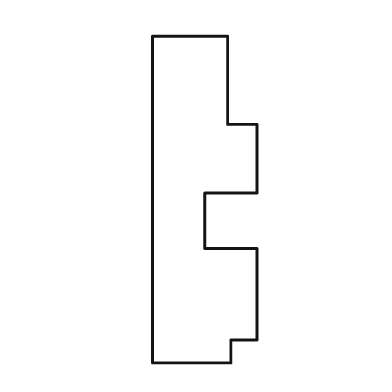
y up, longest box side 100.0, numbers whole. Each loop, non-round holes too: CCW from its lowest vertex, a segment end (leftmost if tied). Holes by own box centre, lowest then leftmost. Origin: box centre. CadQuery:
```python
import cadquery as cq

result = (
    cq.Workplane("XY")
    .moveTo(-16.0, -50.0)
    .lineTo(8.0, -50.0)
    .lineTo(8.0, -43.0)
    .lineTo(16.0, -43.0)
    .lineTo(16.0, -15.0)
    .lineTo(0.0, -15.0)
    .lineTo(0.0, 2.0)
    .lineTo(16.0, 2.0)
    .lineTo(16.0, 23.0)
    .lineTo(7.0, 23.0)
    .lineTo(7.0, 50.0)
    .lineTo(-16.0, 50.0)
    .close()
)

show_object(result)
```